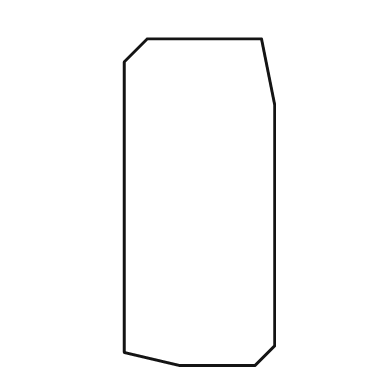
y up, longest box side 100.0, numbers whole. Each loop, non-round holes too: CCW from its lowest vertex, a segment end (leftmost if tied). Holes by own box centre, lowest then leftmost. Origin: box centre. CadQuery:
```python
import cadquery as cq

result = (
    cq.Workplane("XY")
    .moveTo(-6.0, -50.0)
    .lineTo(17.0, -50.0)
    .lineTo(23.0, -44.0)
    .lineTo(23.0, 30.0)
    .lineTo(19.0, 50.0)
    .lineTo(-16.0, 50.0)
    .lineTo(-23.0, 43.0)
    .lineTo(-23.0, -46.0)
    .close()
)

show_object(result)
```